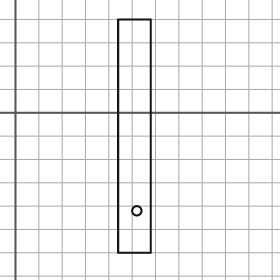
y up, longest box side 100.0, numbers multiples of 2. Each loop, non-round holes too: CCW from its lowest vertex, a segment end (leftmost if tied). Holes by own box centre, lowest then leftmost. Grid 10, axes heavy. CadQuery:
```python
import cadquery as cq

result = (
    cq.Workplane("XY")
    .moveTo(44.0, -60.0)
    .lineTo(58.0, -60.0)
    .lineTo(58.0, 40.0)
    .lineTo(44.0, 40.0)
    .close()
    .moveTo(52.0, -42.0)
    .circle(2.0)
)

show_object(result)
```